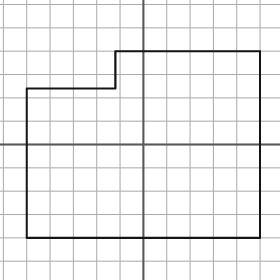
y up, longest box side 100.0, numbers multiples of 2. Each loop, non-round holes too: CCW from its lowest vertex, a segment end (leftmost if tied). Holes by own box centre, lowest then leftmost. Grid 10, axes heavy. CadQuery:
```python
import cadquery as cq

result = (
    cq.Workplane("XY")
    .moveTo(-50.0, -40.0)
    .lineTo(50.0, -40.0)
    .lineTo(50.0, 40.0)
    .lineTo(-12.0, 40.0)
    .lineTo(-12.0, 24.0)
    .lineTo(-50.0, 24.0)
    .close()
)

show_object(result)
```